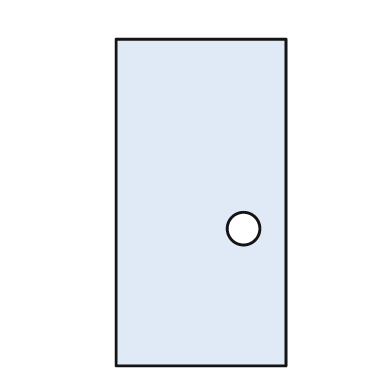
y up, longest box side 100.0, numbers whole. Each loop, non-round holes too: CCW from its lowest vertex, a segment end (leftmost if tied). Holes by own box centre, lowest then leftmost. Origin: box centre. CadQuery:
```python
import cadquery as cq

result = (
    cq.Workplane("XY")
    .moveTo(-26.0, -50.0)
    .lineTo(26.0, -50.0)
    .lineTo(26.0, 50.0)
    .lineTo(-26.0, 50.0)
    .close()
    .moveTo(13.0, -8.0)
    .circle(5.0)
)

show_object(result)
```